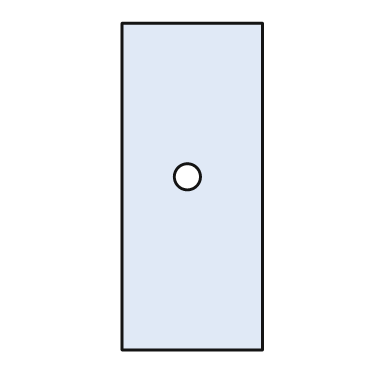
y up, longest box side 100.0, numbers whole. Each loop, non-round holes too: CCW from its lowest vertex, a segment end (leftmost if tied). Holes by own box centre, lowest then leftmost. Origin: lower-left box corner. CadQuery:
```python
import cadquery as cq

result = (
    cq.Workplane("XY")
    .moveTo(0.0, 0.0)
    .lineTo(43.0, 0.0)
    .lineTo(43.0, 100.0)
    .lineTo(0.0, 100.0)
    .close()
    .moveTo(20.0, 53.0)
    .circle(4.0)
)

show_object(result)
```